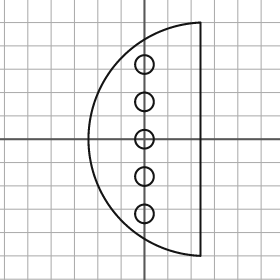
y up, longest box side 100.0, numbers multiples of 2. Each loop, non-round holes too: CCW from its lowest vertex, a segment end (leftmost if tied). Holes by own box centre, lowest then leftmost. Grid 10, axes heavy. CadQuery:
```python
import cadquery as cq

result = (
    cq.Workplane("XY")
    .moveTo(24.0, -50.0)
    .lineTo(24.0, 50.0)
    .threePointArc((-24.0, 0.0), (24.0, -50.0))
    .close()
    .moveTo(0.0, -32.0)
    .circle(4.0)
    .moveTo(0.0, -16.0)
    .circle(4.0)
    .moveTo(0.0, 0.0)
    .circle(4.0)
    .moveTo(0.0, 16.0)
    .circle(4.0)
    .moveTo(0.0, 32.0)
    .circle(4.0)
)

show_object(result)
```